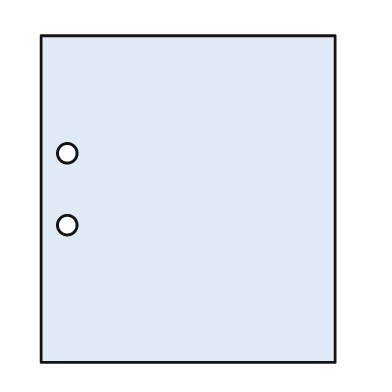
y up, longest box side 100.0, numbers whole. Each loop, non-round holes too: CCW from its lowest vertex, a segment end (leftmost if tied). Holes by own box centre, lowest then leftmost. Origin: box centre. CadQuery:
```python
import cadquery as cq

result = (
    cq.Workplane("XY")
    .moveTo(-45.0, -50.0)
    .lineTo(45.0, -50.0)
    .lineTo(45.0, 50.0)
    .lineTo(-45.0, 50.0)
    .close()
    .moveTo(-37.0, -8.0)
    .circle(3.0)
    .moveTo(-37.0, 14.0)
    .circle(3.0)
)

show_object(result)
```